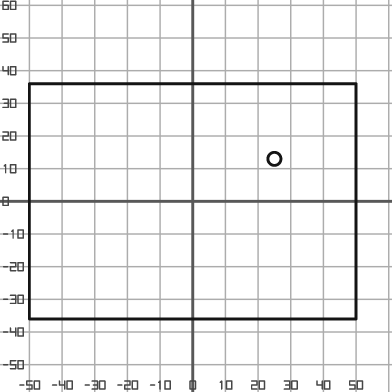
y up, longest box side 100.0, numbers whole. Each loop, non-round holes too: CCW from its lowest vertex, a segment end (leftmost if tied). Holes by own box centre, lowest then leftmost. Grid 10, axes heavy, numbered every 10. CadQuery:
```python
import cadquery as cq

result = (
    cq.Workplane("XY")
    .moveTo(-50.0, -36.0)
    .lineTo(50.0, -36.0)
    .lineTo(50.0, 36.0)
    .lineTo(-50.0, 36.0)
    .close()
    .moveTo(25.0, 13.0)
    .circle(2.0)
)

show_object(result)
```